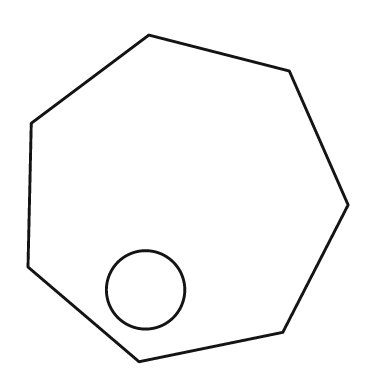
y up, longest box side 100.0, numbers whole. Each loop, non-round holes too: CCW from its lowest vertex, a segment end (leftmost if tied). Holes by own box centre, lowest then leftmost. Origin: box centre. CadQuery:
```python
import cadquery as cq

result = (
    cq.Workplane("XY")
    .moveTo(-15.0, -50.0)
    .lineTo(29.0, -41.0)
    .lineTo(49.0, -2.0)
    .lineTo(31.0, 39.0)
    .lineTo(-12.0, 50.0)
    .lineTo(-48.0, 23.0)
    .lineTo(-49.0, -21.0)
    .close()
    .moveTo(-13.0, -28.0)
    .circle(12.0)
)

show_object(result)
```